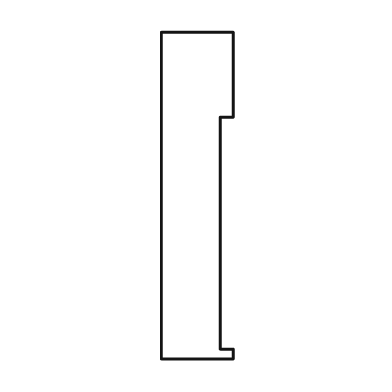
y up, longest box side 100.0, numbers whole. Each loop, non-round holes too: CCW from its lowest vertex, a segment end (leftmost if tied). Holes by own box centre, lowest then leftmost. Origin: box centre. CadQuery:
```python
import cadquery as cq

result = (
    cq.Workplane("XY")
    .moveTo(-11.0, -50.0)
    .lineTo(11.0, -50.0)
    .lineTo(11.0, -47.0)
    .lineTo(7.0, -47.0)
    .lineTo(7.0, 24.0)
    .lineTo(11.0, 24.0)
    .lineTo(11.0, 50.0)
    .lineTo(-11.0, 50.0)
    .close()
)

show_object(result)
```